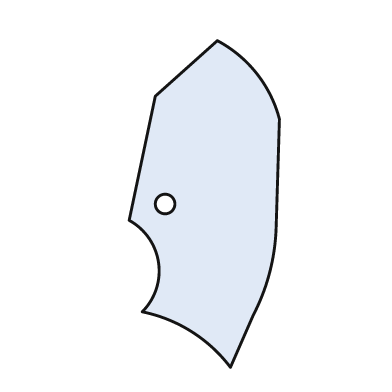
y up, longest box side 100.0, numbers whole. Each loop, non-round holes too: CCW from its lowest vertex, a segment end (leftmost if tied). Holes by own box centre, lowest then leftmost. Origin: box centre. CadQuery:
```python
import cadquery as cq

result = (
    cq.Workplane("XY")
    .moveTo(8.0, -50.0)
    .lineTo(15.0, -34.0)
    .threePointArc((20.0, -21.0), (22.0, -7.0))
    .lineTo(23.0, 26.0)
    .threePointArc((16.0, 40.0), (4.0, 50.0))
    .lineTo(-15.0, 33.0)
    .lineTo(-23.0, -5.0)
    .threePointArc((-14.0, -18.0), (-19.0, -33.0))
    .threePointArc((-4.0, -39.0), (8.0, -50.0))
    .close()
    .moveTo(-12.0, 0.0)
    .circle(3.0)
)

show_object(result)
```